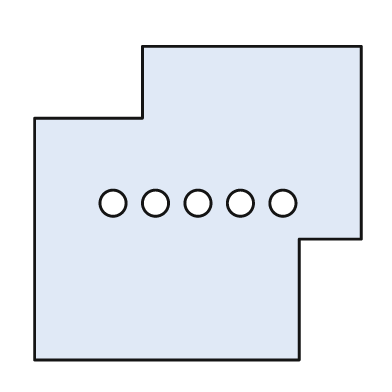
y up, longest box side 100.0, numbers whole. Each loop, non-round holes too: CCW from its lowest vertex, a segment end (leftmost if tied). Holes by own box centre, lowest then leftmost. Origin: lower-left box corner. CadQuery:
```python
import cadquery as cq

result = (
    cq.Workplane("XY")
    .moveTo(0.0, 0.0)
    .lineTo(81.0, 0.0)
    .lineTo(81.0, 37.0)
    .lineTo(100.0, 37.0)
    .lineTo(100.0, 96.0)
    .lineTo(33.0, 96.0)
    .lineTo(33.0, 74.0)
    .lineTo(0.0, 74.0)
    .close()
    .moveTo(24.0, 48.0)
    .circle(4.0)
    .moveTo(37.0, 48.0)
    .circle(4.0)
    .moveTo(50.0, 48.0)
    .circle(4.0)
    .moveTo(63.0, 48.0)
    .circle(4.0)
    .moveTo(76.0, 48.0)
    .circle(4.0)
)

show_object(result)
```